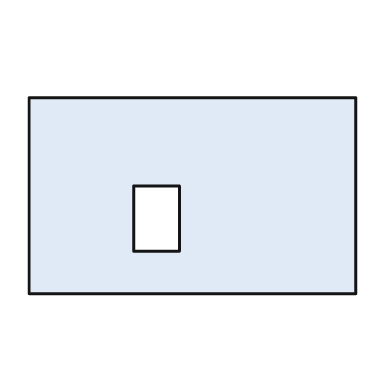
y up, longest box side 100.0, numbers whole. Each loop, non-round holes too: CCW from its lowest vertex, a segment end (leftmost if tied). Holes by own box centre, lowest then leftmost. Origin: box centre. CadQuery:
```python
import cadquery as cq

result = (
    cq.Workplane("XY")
    .moveTo(-50.0, -30.0)
    .lineTo(50.0, -30.0)
    .lineTo(50.0, 30.0)
    .lineTo(-50.0, 30.0)
    .close()
    .moveTo(-18.0, -17.0)
    .lineTo(-4.0, -17.0)
    .lineTo(-4.0, 3.0)
    .lineTo(-18.0, 3.0)
    .close()
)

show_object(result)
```